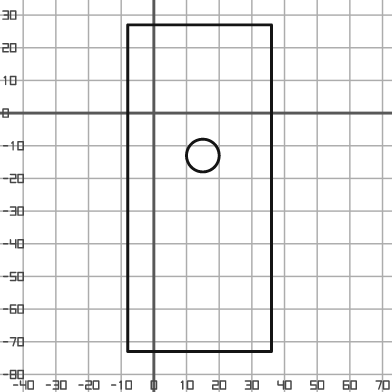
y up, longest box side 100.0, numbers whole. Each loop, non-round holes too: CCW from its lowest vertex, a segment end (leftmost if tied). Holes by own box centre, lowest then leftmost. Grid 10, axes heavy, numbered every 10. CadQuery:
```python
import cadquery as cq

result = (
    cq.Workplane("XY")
    .moveTo(-8.0, -73.0)
    .lineTo(36.0, -73.0)
    .lineTo(36.0, 27.0)
    .lineTo(-8.0, 27.0)
    .close()
    .moveTo(15.0, -13.0)
    .circle(5.0)
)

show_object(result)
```